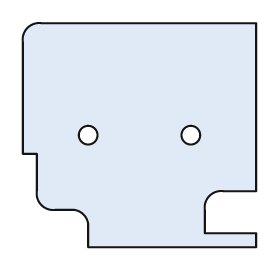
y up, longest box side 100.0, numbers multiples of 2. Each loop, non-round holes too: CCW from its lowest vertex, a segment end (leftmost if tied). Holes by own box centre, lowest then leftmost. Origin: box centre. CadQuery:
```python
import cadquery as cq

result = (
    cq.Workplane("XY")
    .moveTo(-22.0, -48.0)
    .lineTo(50.0, -48.0)
    .lineTo(50.0, -42.0)
    .lineTo(28.0, -42.0)
    .lineTo(28.0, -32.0)
    .threePointArc((30.0, -26.0), (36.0, -24.0))
    .lineTo(50.0, -24.0)
    .lineTo(50.0, 48.0)
    .lineTo(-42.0, 48.0)
    .threePointArc((-48.0, 46.0), (-50.0, 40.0))
    .lineTo(-50.0, -8.0)
    .lineTo(-44.0, -8.0)
    .lineTo(-44.0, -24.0)
    .threePointArc((-42.0, -30.0), (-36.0, -32.0))
    .lineTo(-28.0, -32.0)
    .threePointArc((-24.0, -34.0), (-22.0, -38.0))
    .close()
    .moveTo(-22.0, 0.0)
    .circle(4.0)
    .moveTo(22.0, 0.0)
    .circle(4.0)
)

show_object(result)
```